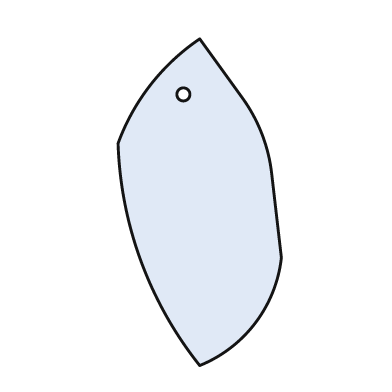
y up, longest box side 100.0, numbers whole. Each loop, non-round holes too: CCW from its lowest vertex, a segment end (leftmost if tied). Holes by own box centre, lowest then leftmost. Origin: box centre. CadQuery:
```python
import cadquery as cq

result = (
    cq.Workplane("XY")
    .moveTo(0.0, -50.0)
    .threePointArc((17.0, -37.0), (25.0, -17.0))
    .lineTo(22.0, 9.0)
    .threePointArc((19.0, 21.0), (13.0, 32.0))
    .lineTo(0.0, 50.0)
    .threePointArc((-15.0, 36.0), (-25.0, 18.0))
    .threePointArc((-18.0, -18.0), (0.0, -50.0))
    .close()
    .moveTo(-5.0, 33.0)
    .circle(2.0)
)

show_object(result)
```